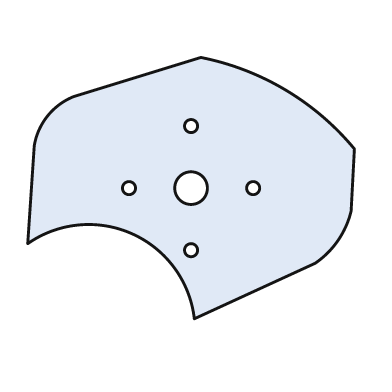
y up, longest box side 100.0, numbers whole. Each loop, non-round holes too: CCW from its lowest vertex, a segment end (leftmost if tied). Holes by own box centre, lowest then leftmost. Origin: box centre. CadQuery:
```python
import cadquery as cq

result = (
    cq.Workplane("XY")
    .moveTo(1.0, -40.0)
    .lineTo(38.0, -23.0)
    .threePointArc((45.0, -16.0), (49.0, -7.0))
    .lineTo(50.0, 12.0)
    .threePointArc((29.0, 30.0), (3.0, 40.0))
    .lineTo(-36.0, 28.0)
    .threePointArc((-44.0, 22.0), (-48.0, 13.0))
    .lineTo(-50.0, -17.0)
    .threePointArc((-18.0, -14.0), (1.0, -40.0))
    .close()
    .moveTo(0.0, -19.0)
    .circle(2.0)
    .moveTo(-19.0, 0.0)
    .circle(2.0)
    .moveTo(0.0, 0.0)
    .circle(5.0)
    .moveTo(19.0, 0.0)
    .circle(2.0)
    .moveTo(0.0, 19.0)
    .circle(2.0)
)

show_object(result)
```